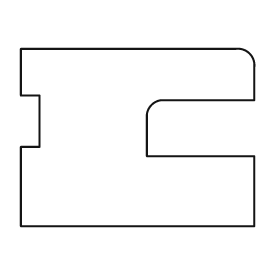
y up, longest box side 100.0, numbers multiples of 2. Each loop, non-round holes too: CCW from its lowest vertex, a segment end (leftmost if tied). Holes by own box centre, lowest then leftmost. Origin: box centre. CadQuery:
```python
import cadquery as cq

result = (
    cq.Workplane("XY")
    .moveTo(-50.0, -38.0)
    .lineTo(50.0, -38.0)
    .lineTo(50.0, -8.0)
    .lineTo(4.0, -8.0)
    .lineTo(4.0, 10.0)
    .threePointArc((6.0, 14.0), (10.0, 16.0))
    .lineTo(50.0, 16.0)
    .lineTo(50.0, 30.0)
    .threePointArc((48.0, 36.0), (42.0, 38.0))
    .lineTo(-50.0, 38.0)
    .lineTo(-50.0, 18.0)
    .lineTo(-42.0, 18.0)
    .lineTo(-42.0, -4.0)
    .lineTo(-50.0, -4.0)
    .close()
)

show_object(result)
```